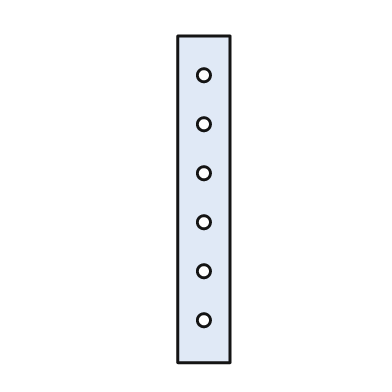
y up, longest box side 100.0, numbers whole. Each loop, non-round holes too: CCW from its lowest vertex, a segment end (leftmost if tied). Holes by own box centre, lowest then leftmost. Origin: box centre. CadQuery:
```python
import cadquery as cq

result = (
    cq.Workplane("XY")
    .moveTo(-8.0, -50.0)
    .lineTo(8.0, -50.0)
    .lineTo(8.0, 50.0)
    .lineTo(-8.0, 50.0)
    .close()
    .moveTo(0.0, -37.0)
    .circle(2.0)
    .moveTo(0.0, -22.0)
    .circle(2.0)
    .moveTo(0.0, -7.0)
    .circle(2.0)
    .moveTo(0.0, 8.0)
    .circle(2.0)
    .moveTo(0.0, 23.0)
    .circle(2.0)
    .moveTo(0.0, 38.0)
    .circle(2.0)
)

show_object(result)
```